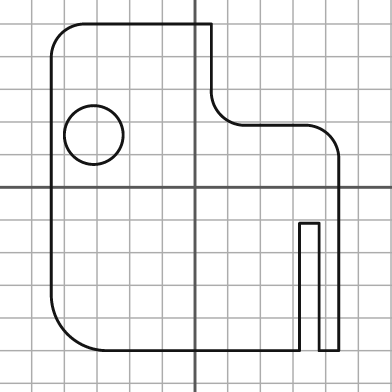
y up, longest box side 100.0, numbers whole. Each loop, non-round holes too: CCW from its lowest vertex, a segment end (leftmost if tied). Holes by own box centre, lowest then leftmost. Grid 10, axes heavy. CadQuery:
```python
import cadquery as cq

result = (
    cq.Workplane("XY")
    .moveTo(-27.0, -50.0)
    .lineTo(32.0, -50.0)
    .lineTo(32.0, -11.0)
    .lineTo(38.0, -11.0)
    .lineTo(38.0, -50.0)
    .lineTo(44.0, -50.0)
    .lineTo(44.0, 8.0)
    .threePointArc((41.0, 16.0), (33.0, 19.0))
    .lineTo(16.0, 19.0)
    .threePointArc((8.0, 22.0), (5.0, 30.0))
    .lineTo(5.0, 50.0)
    .lineTo(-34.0, 50.0)
    .threePointArc((-41.0, 47.0), (-44.0, 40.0))
    .lineTo(-44.0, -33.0)
    .threePointArc((-39.0, -45.0), (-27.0, -50.0))
    .close()
    .moveTo(-31.0, 16.0)
    .circle(9.0)
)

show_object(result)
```